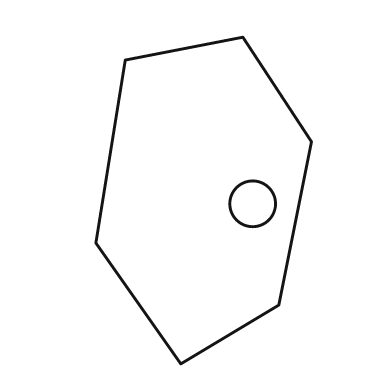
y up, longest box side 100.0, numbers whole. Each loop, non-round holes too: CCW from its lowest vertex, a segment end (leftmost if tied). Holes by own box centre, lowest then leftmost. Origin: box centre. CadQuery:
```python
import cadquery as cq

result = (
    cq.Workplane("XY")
    .moveTo(-7.0, -50.0)
    .lineTo(23.0, -32.0)
    .lineTo(33.0, 18.0)
    .lineTo(12.0, 50.0)
    .lineTo(-24.0, 43.0)
    .lineTo(-33.0, -13.0)
    .close()
    .moveTo(15.0, -1.0)
    .circle(7.0)
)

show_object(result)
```